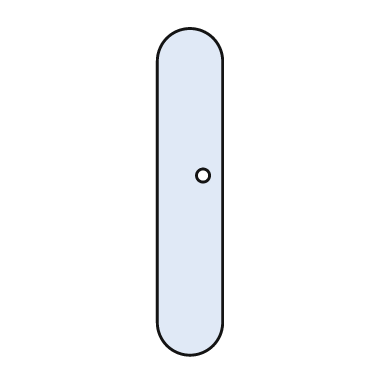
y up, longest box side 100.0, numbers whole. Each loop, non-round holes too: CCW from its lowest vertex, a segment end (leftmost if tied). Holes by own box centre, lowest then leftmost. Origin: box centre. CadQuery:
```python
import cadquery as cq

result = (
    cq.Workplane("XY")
    .moveTo(-10.0, -40.0)
    .threePointArc((0.0, -50.0), (10.0, -40.0))
    .lineTo(10.0, 40.0)
    .threePointArc((0.0, 50.0), (-10.0, 40.0))
    .close()
    .moveTo(4.0, 5.0)
    .circle(2.0)
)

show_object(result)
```